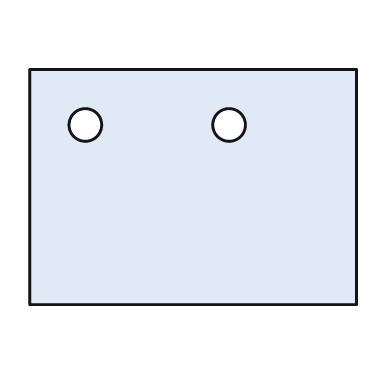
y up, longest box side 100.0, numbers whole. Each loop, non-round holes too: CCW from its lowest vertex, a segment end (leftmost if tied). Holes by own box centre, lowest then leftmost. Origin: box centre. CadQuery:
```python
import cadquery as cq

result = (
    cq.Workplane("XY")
    .moveTo(-50.0, -36.0)
    .lineTo(50.0, -36.0)
    .lineTo(50.0, 36.0)
    .lineTo(-50.0, 36.0)
    .close()
    .moveTo(-33.0, 19.0)
    .circle(5.0)
    .moveTo(11.0, 19.0)
    .circle(5.0)
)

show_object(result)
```